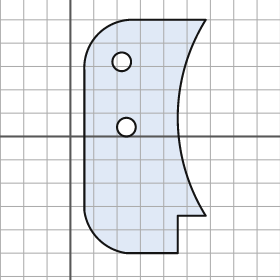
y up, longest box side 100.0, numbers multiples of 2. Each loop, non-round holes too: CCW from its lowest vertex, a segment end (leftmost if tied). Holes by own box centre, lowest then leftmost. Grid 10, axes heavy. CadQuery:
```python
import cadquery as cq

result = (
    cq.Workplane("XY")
    .moveTo(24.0, -50.0)
    .lineTo(46.0, -50.0)
    .lineTo(46.0, -34.0)
    .lineTo(58.0, -34.0)
    .threePointArc((46.0, 8.0), (58.0, 50.0))
    .lineTo(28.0, 50.0)
    .threePointArc((12.0, 44.0), (6.0, 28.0))
    .lineTo(6.0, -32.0)
    .threePointArc((12.0, -44.0), (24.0, -50.0))
    .close()
    .moveTo(24.0, 4.0)
    .circle(4.0)
    .moveTo(22.0, 32.0)
    .circle(4.0)
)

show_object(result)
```